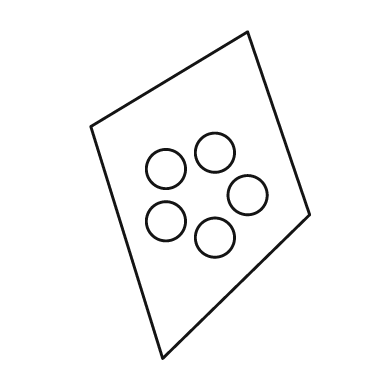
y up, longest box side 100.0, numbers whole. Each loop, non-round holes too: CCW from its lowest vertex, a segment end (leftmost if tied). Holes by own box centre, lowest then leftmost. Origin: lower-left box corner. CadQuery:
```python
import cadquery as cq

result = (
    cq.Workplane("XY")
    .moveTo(22.0, 0.0)
    .lineTo(67.0, 44.0)
    .lineTo(48.0, 100.0)
    .lineTo(0.0, 71.0)
    .close()
    .moveTo(38.0, 37.0)
    .circle(6.0)
    .moveTo(23.0, 42.0)
    .circle(6.0)
    .moveTo(48.0, 50.0)
    .circle(6.0)
    .moveTo(23.0, 58.0)
    .circle(6.0)
    .moveTo(38.0, 63.0)
    .circle(6.0)
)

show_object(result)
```